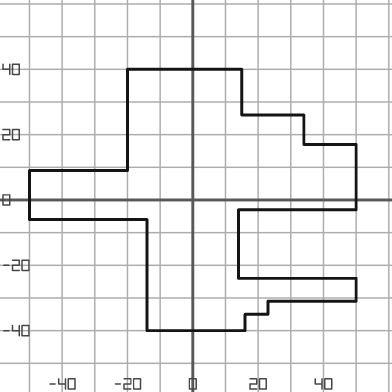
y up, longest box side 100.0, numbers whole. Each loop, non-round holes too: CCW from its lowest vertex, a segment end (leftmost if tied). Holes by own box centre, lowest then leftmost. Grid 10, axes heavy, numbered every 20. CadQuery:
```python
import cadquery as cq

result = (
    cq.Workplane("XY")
    .moveTo(-14.0, -40.0)
    .lineTo(16.0, -40.0)
    .lineTo(16.0, -35.0)
    .lineTo(23.0, -35.0)
    .lineTo(23.0, -31.0)
    .lineTo(50.0, -31.0)
    .lineTo(50.0, -24.0)
    .lineTo(14.0, -24.0)
    .lineTo(14.0, -3.0)
    .lineTo(50.0, -3.0)
    .lineTo(50.0, 17.0)
    .lineTo(34.0, 17.0)
    .lineTo(34.0, 26.0)
    .lineTo(15.0, 26.0)
    .lineTo(15.0, 40.0)
    .lineTo(-20.0, 40.0)
    .lineTo(-20.0, 9.0)
    .lineTo(-50.0, 9.0)
    .lineTo(-50.0, -6.0)
    .lineTo(-14.0, -6.0)
    .close()
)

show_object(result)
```